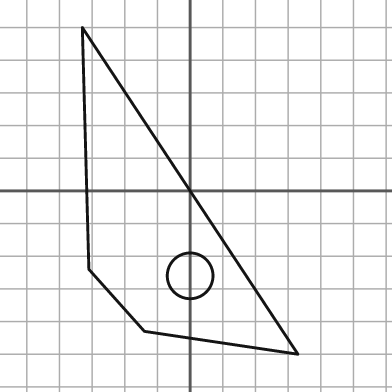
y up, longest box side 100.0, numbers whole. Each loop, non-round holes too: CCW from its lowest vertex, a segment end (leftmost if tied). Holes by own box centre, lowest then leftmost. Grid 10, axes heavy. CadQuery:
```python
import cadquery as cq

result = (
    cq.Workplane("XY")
    .moveTo(33.0, -50.0)
    .lineTo(-33.0, 50.0)
    .lineTo(-31.0, -24.0)
    .lineTo(-14.0, -43.0)
    .close()
    .moveTo(0.0, -26.0)
    .circle(7.0)
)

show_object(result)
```